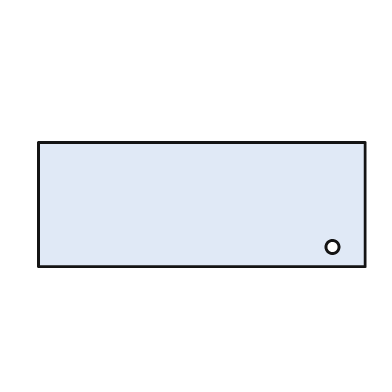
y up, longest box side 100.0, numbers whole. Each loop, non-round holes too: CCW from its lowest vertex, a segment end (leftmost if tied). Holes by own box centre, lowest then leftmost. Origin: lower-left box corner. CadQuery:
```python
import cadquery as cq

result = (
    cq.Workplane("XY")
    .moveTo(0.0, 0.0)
    .lineTo(100.0, 0.0)
    .lineTo(100.0, 38.0)
    .lineTo(0.0, 38.0)
    .close()
    .moveTo(90.0, 6.0)
    .circle(2.0)
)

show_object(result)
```